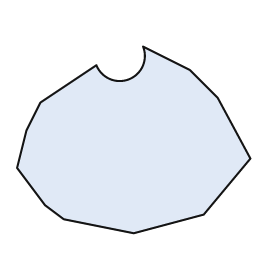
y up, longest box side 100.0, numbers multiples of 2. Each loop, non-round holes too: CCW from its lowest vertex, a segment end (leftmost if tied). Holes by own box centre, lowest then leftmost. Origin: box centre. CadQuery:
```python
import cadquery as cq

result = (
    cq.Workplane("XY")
    .moveTo(0.0, -40.0)
    .lineTo(30.0, -32.0)
    .lineTo(50.0, -8.0)
    .lineTo(36.0, 18.0)
    .lineTo(24.0, 30.0)
    .lineTo(4.0, 40.0)
    .threePointArc((-2.0, 26.0), (-16.0, 32.0))
    .lineTo(-40.0, 16.0)
    .lineTo(-46.0, 4.0)
    .lineTo(-50.0, -12.0)
    .lineTo(-38.0, -28.0)
    .lineTo(-30.0, -34.0)
    .close()
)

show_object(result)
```